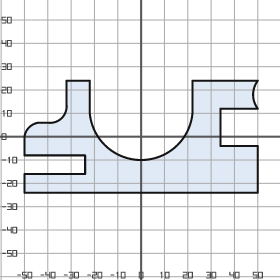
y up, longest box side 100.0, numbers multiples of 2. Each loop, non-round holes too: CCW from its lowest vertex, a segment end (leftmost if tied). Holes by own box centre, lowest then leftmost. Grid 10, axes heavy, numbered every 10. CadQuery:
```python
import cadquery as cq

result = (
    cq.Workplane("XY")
    .moveTo(-50.0, -24.0)
    .lineTo(50.0, -24.0)
    .lineTo(50.0, -4.0)
    .lineTo(34.0, -4.0)
    .lineTo(34.0, 12.0)
    .lineTo(50.0, 12.0)
    .threePointArc((48.0, 18.0), (50.0, 24.0))
    .lineTo(22.0, 24.0)
    .lineTo(22.0, 10.0)
    .threePointArc((0.0, -10.0), (-22.0, 10.0))
    .lineTo(-22.0, 24.0)
    .lineTo(-32.0, 24.0)
    .lineTo(-32.0, 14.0)
    .threePointArc((-34.0, 8.0), (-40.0, 6.0))
    .lineTo(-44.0, 6.0)
    .threePointArc((-48.0, 4.0), (-50.0, 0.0))
    .lineTo(-50.0, -8.0)
    .lineTo(-24.0, -8.0)
    .lineTo(-24.0, -16.0)
    .lineTo(-50.0, -16.0)
    .close()
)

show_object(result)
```